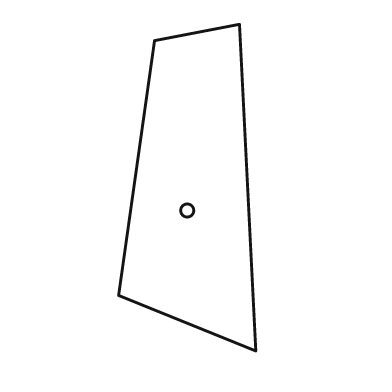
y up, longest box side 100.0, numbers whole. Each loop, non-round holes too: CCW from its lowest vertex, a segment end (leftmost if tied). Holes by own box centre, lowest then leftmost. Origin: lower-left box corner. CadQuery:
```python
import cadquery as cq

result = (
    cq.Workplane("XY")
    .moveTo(42.0, 0.0)
    .lineTo(37.0, 100.0)
    .lineTo(11.0, 95.0)
    .lineTo(0.0, 17.0)
    .close()
    .moveTo(21.0, 43.0)
    .circle(2.0)
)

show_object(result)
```